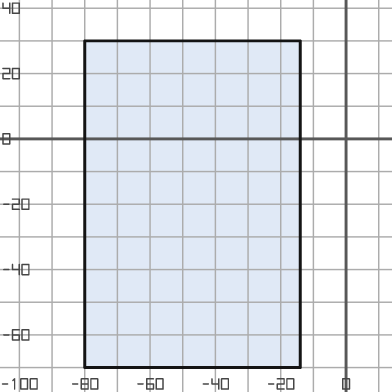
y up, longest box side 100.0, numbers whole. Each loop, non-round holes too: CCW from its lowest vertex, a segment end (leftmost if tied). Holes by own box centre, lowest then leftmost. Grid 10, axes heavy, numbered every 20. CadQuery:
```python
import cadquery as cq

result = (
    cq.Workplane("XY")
    .moveTo(-80.0, -70.0)
    .lineTo(-14.0, -70.0)
    .lineTo(-14.0, 30.0)
    .lineTo(-80.0, 30.0)
    .close()
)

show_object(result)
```